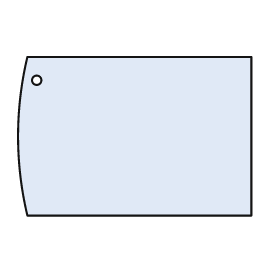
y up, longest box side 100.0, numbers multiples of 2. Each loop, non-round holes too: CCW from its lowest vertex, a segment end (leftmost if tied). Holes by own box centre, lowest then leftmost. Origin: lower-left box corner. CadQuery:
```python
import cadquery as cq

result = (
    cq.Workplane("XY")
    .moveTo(4.0, 0.0)
    .lineTo(100.0, 0.0)
    .lineTo(100.0, 68.0)
    .lineTo(4.0, 68.0)
    .threePointArc((0.0, 34.0), (4.0, 0.0))
    .close()
    .moveTo(8.0, 58.0)
    .circle(2.0)
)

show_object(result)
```